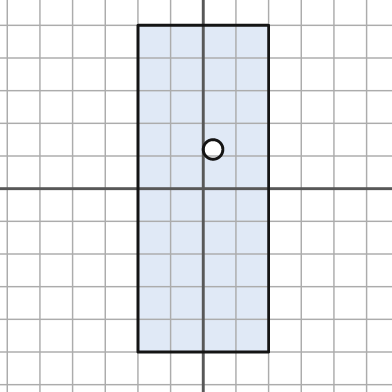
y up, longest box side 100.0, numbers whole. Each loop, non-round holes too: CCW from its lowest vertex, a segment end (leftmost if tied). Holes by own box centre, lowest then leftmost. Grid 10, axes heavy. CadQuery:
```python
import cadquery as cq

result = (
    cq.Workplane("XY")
    .moveTo(-20.0, -50.0)
    .lineTo(20.0, -50.0)
    .lineTo(20.0, 50.0)
    .lineTo(-20.0, 50.0)
    .close()
    .moveTo(3.0, 12.0)
    .circle(3.0)
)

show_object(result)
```